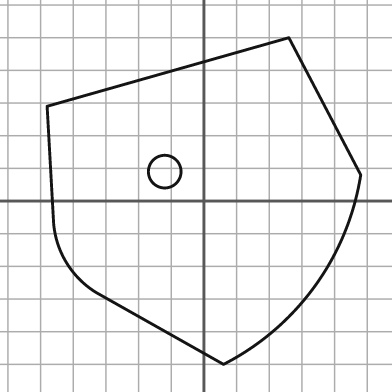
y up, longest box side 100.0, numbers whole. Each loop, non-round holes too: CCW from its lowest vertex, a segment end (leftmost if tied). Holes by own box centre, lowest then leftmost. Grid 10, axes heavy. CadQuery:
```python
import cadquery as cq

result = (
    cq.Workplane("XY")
    .moveTo(6.0, -50.0)
    .threePointArc((34.0, -26.0), (48.0, 8.0))
    .lineTo(26.0, 50.0)
    .lineTo(-48.0, 29.0)
    .lineTo(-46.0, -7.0)
    .threePointArc((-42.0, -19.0), (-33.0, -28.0))
    .close()
    .moveTo(-12.0, 9.0)
    .circle(5.0)
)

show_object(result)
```